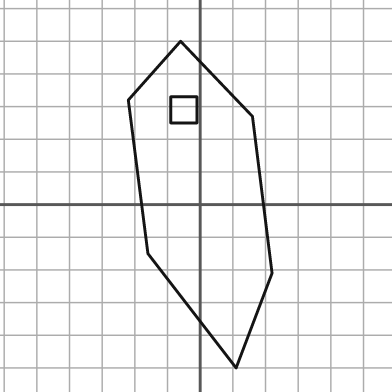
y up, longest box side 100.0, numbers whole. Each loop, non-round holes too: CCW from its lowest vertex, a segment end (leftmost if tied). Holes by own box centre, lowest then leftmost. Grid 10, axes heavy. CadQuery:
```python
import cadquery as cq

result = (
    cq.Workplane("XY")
    .moveTo(11.0, -50.0)
    .lineTo(22.0, -21.0)
    .lineTo(16.0, 27.0)
    .lineTo(-6.0, 50.0)
    .lineTo(-22.0, 32.0)
    .lineTo(-16.0, -15.0)
    .close()
    .moveTo(-9.0, 25.0)
    .lineTo(-1.0, 25.0)
    .lineTo(-1.0, 33.0)
    .lineTo(-9.0, 33.0)
    .close()
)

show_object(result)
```